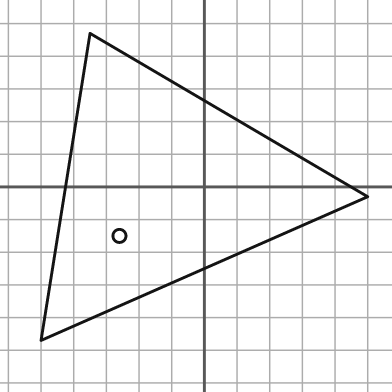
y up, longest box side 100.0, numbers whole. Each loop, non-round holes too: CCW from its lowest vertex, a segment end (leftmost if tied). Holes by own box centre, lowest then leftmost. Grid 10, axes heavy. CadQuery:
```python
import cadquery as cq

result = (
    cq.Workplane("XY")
    .moveTo(-50.0, -47.0)
    .lineTo(50.0, -3.0)
    .lineTo(-35.0, 47.0)
    .close()
    .moveTo(-26.0, -15.0)
    .circle(2.0)
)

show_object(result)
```